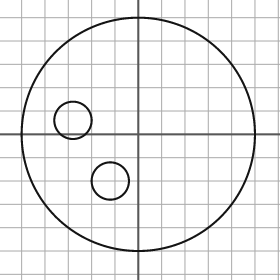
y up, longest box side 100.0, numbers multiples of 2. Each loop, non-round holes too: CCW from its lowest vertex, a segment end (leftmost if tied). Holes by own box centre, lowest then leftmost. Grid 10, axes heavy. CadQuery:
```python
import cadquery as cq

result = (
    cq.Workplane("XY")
    .moveTo(0.0, 0.0)
    .circle(50.0)
    .moveTo(-12.0, -20.0)
    .circle(8.0)
    .moveTo(-28.0, 6.0)
    .circle(8.0)
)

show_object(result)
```